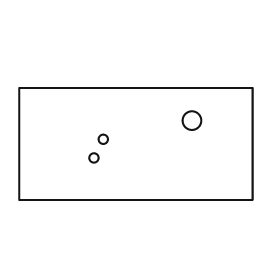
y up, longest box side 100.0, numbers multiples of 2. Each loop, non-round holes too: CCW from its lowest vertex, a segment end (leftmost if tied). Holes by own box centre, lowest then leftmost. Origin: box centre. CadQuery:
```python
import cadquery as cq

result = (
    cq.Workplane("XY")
    .moveTo(-50.0, -24.0)
    .lineTo(50.0, -24.0)
    .lineTo(50.0, 24.0)
    .lineTo(-50.0, 24.0)
    .close()
    .moveTo(-18.0, -6.0)
    .circle(2.0)
    .moveTo(-14.0, 2.0)
    .circle(2.0)
    .moveTo(24.0, 10.0)
    .circle(4.0)
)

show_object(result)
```